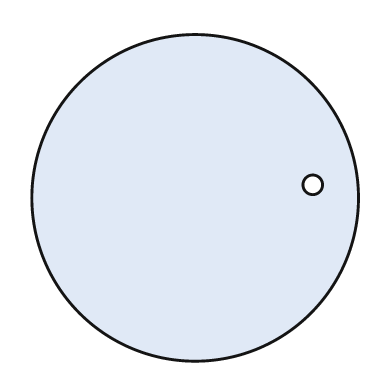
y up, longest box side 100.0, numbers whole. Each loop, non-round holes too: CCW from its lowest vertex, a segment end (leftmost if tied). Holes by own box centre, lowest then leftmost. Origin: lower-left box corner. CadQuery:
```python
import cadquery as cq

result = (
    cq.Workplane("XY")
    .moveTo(50.0, 50.0)
    .circle(50.0)
    .moveTo(86.0, 54.0)
    .circle(3.0)
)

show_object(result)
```